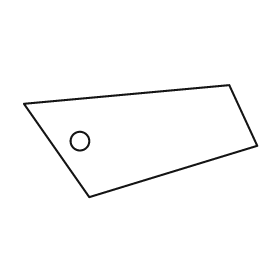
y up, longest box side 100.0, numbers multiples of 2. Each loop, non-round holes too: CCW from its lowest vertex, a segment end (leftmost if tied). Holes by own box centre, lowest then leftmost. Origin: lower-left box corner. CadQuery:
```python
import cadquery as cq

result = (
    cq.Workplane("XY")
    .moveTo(28.0, 0.0)
    .lineTo(100.0, 22.0)
    .lineTo(88.0, 48.0)
    .lineTo(0.0, 40.0)
    .close()
    .moveTo(24.0, 24.0)
    .circle(4.0)
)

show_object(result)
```